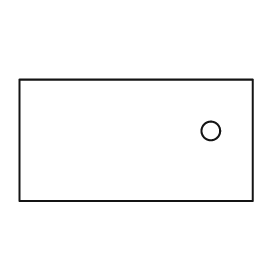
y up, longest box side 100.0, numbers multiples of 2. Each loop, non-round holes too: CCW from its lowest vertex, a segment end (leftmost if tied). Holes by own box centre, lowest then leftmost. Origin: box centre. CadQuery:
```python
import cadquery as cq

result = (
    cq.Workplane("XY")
    .moveTo(-50.0, -26.0)
    .lineTo(50.0, -26.0)
    .lineTo(50.0, 26.0)
    .lineTo(-50.0, 26.0)
    .close()
    .moveTo(32.0, 4.0)
    .circle(4.0)
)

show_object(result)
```